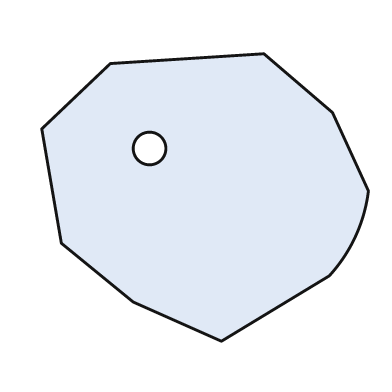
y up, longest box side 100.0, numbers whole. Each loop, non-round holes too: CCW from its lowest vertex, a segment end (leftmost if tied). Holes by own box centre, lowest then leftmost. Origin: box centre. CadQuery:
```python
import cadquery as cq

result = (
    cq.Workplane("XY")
    .moveTo(5.0, -44.0)
    .lineTo(38.0, -24.0)
    .threePointArc((46.0, -12.0), (50.0, 2.0))
    .lineTo(39.0, 26.0)
    .lineTo(18.0, 44.0)
    .lineTo(-29.0, 41.0)
    .lineTo(-50.0, 21.0)
    .lineTo(-44.0, -14.0)
    .lineTo(-22.0, -32.0)
    .close()
    .moveTo(-17.0, 15.0)
    .circle(5.0)
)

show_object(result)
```